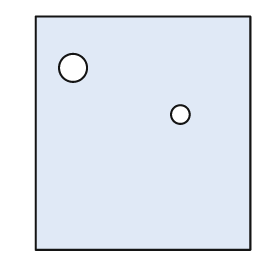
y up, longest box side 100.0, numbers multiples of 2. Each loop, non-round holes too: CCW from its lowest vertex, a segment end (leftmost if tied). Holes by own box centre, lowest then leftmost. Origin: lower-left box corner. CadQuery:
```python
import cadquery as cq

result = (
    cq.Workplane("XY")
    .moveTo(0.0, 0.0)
    .lineTo(92.0, 0.0)
    .lineTo(92.0, 100.0)
    .lineTo(0.0, 100.0)
    .close()
    .moveTo(62.0, 58.0)
    .circle(4.0)
    .moveTo(16.0, 78.0)
    .circle(6.0)
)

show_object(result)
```